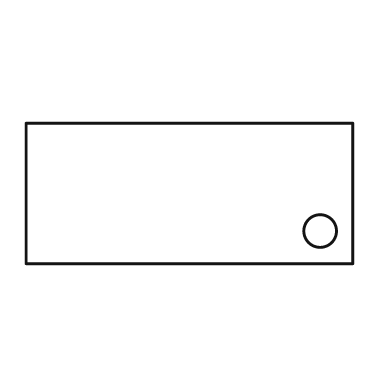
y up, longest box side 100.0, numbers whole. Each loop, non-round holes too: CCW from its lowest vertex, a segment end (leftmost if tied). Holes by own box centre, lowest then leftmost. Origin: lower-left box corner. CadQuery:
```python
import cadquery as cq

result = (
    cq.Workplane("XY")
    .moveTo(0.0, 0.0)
    .lineTo(100.0, 0.0)
    .lineTo(100.0, 43.0)
    .lineTo(0.0, 43.0)
    .close()
    .moveTo(90.0, 10.0)
    .circle(5.0)
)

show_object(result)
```